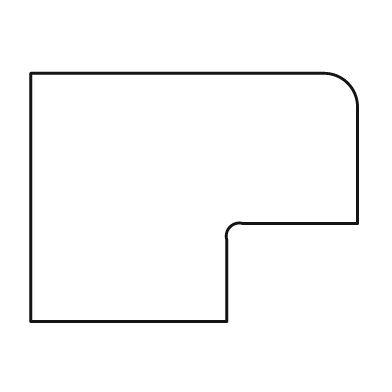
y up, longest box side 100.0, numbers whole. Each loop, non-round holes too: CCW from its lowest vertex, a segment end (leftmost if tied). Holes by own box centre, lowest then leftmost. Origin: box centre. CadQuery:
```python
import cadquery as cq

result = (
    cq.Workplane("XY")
    .moveTo(-50.0, -38.0)
    .lineTo(10.0, -38.0)
    .lineTo(10.0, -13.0)
    .threePointArc((11.0, -9.0), (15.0, -8.0))
    .lineTo(50.0, -8.0)
    .lineTo(50.0, 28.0)
    .threePointArc((47.0, 35.0), (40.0, 38.0))
    .lineTo(-50.0, 38.0)
    .close()
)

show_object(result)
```